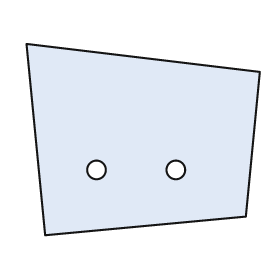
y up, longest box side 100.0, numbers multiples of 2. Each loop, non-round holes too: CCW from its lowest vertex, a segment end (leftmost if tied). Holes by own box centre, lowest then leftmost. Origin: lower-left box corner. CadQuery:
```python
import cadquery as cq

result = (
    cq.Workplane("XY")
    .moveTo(8.0, 0.0)
    .lineTo(94.0, 8.0)
    .lineTo(100.0, 70.0)
    .lineTo(0.0, 82.0)
    .close()
    .moveTo(30.0, 28.0)
    .circle(4.0)
    .moveTo(64.0, 28.0)
    .circle(4.0)
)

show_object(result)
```